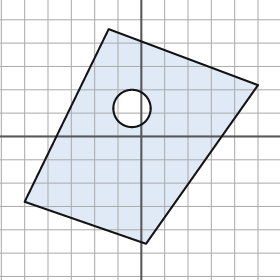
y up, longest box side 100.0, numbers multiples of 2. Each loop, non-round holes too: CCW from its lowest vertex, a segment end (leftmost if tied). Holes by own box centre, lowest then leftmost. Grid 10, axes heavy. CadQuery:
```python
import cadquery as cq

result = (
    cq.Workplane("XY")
    .moveTo(2.0, -46.0)
    .lineTo(50.0, 22.0)
    .lineTo(-14.0, 46.0)
    .lineTo(-50.0, -28.0)
    .close()
    .moveTo(-4.0, 12.0)
    .circle(8.0)
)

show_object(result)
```